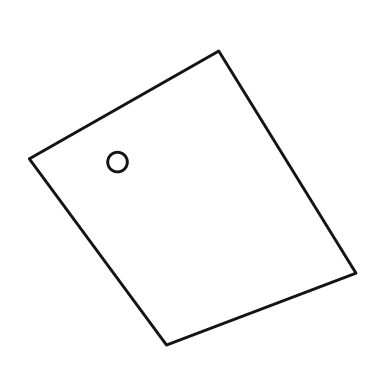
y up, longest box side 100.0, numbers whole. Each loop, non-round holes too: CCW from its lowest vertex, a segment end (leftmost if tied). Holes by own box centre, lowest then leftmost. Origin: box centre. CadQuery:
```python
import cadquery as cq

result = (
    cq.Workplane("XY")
    .moveTo(-8.0, -45.0)
    .lineTo(50.0, -23.0)
    .lineTo(8.0, 45.0)
    .lineTo(-50.0, 12.0)
    .close()
    .moveTo(-23.0, 11.0)
    .circle(3.0)
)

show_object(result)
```